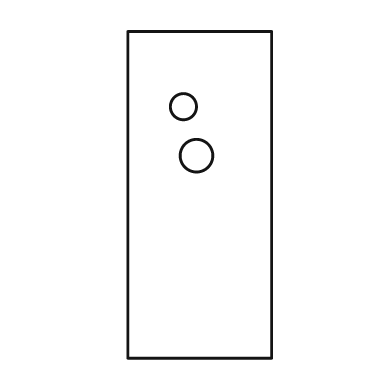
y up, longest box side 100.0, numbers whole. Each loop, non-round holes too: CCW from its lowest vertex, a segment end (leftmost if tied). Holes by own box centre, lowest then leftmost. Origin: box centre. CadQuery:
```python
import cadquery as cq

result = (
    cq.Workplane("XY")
    .moveTo(-22.0, -50.0)
    .lineTo(22.0, -50.0)
    .lineTo(22.0, 50.0)
    .lineTo(-22.0, 50.0)
    .close()
    .moveTo(-1.0, 12.0)
    .circle(5.0)
    .moveTo(-5.0, 27.0)
    .circle(4.0)
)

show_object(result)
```